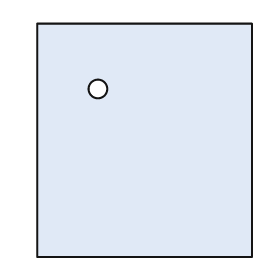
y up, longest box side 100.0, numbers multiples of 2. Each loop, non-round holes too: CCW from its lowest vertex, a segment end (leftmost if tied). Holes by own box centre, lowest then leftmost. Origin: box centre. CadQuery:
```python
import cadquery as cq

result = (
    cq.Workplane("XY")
    .moveTo(-46.0, -50.0)
    .lineTo(46.0, -50.0)
    .lineTo(46.0, 50.0)
    .lineTo(-46.0, 50.0)
    .close()
    .moveTo(-20.0, 22.0)
    .circle(4.0)
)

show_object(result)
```